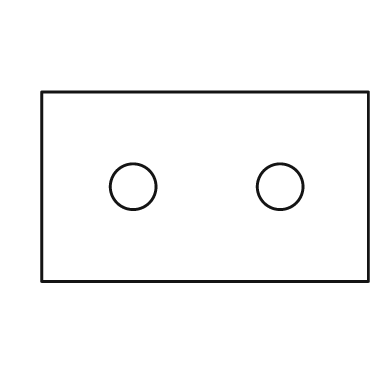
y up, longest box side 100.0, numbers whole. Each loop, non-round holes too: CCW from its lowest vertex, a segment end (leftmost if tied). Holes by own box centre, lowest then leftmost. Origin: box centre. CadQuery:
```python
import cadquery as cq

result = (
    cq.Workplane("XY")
    .moveTo(-50.0, -29.0)
    .lineTo(50.0, -29.0)
    .lineTo(50.0, 29.0)
    .lineTo(-50.0, 29.0)
    .close()
    .moveTo(-22.0, 0.0)
    .circle(7.0)
    .moveTo(23.0, 0.0)
    .circle(7.0)
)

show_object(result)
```